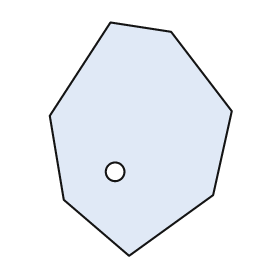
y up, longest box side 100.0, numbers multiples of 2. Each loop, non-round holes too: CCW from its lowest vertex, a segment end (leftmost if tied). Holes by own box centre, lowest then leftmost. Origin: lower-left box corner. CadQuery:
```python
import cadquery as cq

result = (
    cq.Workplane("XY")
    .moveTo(34.0, 0.0)
    .lineTo(70.0, 26.0)
    .lineTo(78.0, 62.0)
    .lineTo(52.0, 96.0)
    .lineTo(26.0, 100.0)
    .lineTo(0.0, 60.0)
    .lineTo(6.0, 24.0)
    .close()
    .moveTo(28.0, 36.0)
    .circle(4.0)
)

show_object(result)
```